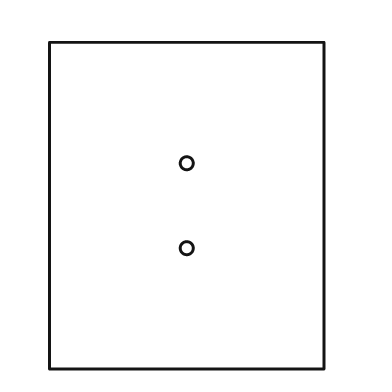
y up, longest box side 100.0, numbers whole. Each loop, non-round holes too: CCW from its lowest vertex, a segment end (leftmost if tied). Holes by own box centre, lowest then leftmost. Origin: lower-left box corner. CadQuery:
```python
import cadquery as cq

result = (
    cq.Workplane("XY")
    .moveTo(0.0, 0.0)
    .lineTo(84.0, 0.0)
    .lineTo(84.0, 100.0)
    .lineTo(0.0, 100.0)
    .close()
    .moveTo(42.0, 37.0)
    .circle(2.0)
    .moveTo(42.0, 63.0)
    .circle(2.0)
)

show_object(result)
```